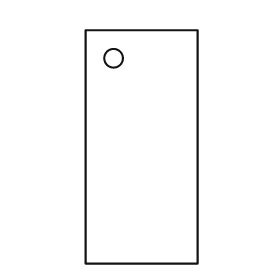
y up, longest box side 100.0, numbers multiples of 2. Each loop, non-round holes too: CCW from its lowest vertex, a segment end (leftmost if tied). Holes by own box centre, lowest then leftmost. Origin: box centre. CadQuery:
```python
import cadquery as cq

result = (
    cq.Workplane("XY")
    .moveTo(-24.0, -50.0)
    .lineTo(24.0, -50.0)
    .lineTo(24.0, 50.0)
    .lineTo(-24.0, 50.0)
    .close()
    .moveTo(-12.0, 38.0)
    .circle(4.0)
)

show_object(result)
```